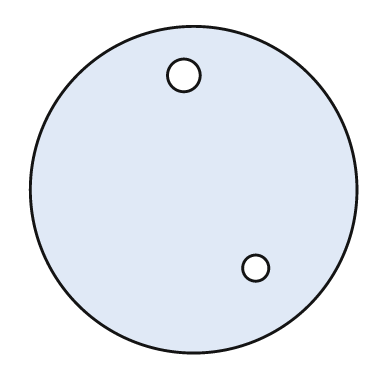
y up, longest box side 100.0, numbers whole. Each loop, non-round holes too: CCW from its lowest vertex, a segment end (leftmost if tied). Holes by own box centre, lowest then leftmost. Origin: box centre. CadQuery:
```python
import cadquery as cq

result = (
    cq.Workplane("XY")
    .moveTo(0.0, 0.0)
    .circle(50.0)
    .moveTo(19.0, -24.0)
    .circle(4.0)
    .moveTo(-3.0, 35.0)
    .circle(5.0)
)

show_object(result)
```